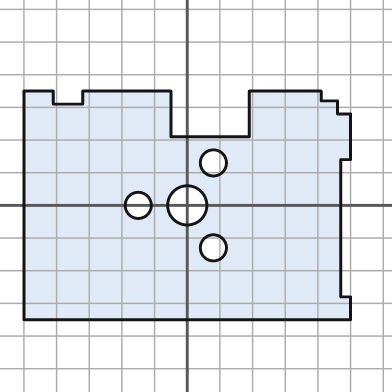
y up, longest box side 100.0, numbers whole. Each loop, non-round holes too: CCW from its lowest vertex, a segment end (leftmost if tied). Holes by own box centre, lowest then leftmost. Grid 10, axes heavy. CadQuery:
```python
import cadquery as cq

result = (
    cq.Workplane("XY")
    .moveTo(-50.0, -35.0)
    .lineTo(50.0, -35.0)
    .lineTo(50.0, -28.0)
    .lineTo(47.0, -28.0)
    .lineTo(47.0, 14.0)
    .lineTo(50.0, 14.0)
    .lineTo(50.0, 28.0)
    .lineTo(46.0, 28.0)
    .lineTo(46.0, 32.0)
    .lineTo(41.0, 32.0)
    .lineTo(41.0, 35.0)
    .lineTo(19.0, 35.0)
    .lineTo(19.0, 21.0)
    .lineTo(-5.0, 21.0)
    .lineTo(-5.0, 35.0)
    .lineTo(-32.0, 35.0)
    .lineTo(-32.0, 31.0)
    .lineTo(-41.0, 31.0)
    .lineTo(-41.0, 35.0)
    .lineTo(-50.0, 35.0)
    .close()
    .moveTo(8.0, -13.0)
    .circle(4.0)
    .moveTo(-15.0, 0.0)
    .circle(4.0)
    .moveTo(0.0, 0.0)
    .circle(6.0)
    .moveTo(8.0, 13.0)
    .circle(4.0)
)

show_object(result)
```